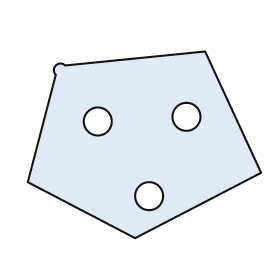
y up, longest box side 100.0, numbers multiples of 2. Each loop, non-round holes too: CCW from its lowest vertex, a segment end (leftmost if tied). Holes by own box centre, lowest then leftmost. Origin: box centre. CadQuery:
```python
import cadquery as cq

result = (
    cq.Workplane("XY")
    .moveTo(-4.0, -40.0)
    .lineTo(50.0, -12.0)
    .lineTo(26.0, 40.0)
    .lineTo(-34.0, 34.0)
    .threePointArc((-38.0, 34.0), (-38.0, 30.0))
    .lineTo(-50.0, -16.0)
    .close()
    .moveTo(2.0, -22.0)
    .circle(6.0)
    .moveTo(-20.0, 10.0)
    .circle(6.0)
    .moveTo(18.0, 12.0)
    .circle(6.0)
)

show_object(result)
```